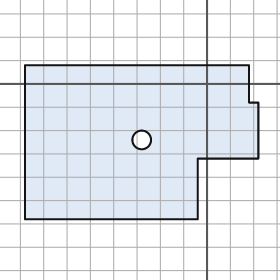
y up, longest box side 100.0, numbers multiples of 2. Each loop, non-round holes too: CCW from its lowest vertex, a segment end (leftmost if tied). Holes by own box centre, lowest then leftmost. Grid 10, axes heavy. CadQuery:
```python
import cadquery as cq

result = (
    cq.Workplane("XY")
    .moveTo(-78.0, -58.0)
    .lineTo(-4.0, -58.0)
    .lineTo(-4.0, -32.0)
    .lineTo(22.0, -32.0)
    .lineTo(22.0, -8.0)
    .lineTo(18.0, -8.0)
    .lineTo(18.0, 8.0)
    .lineTo(-78.0, 8.0)
    .close()
    .moveTo(-28.0, -24.0)
    .circle(4.0)
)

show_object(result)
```